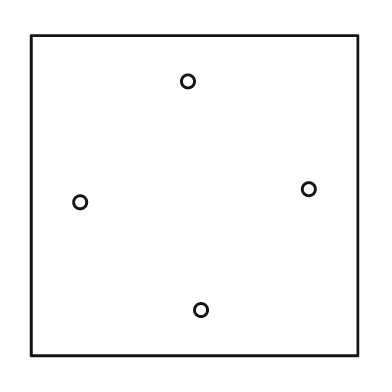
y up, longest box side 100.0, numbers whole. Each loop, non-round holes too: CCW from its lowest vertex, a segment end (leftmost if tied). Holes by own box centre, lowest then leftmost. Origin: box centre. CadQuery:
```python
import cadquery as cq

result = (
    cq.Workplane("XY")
    .moveTo(-50.0, -49.0)
    .lineTo(50.0, -49.0)
    .lineTo(50.0, 49.0)
    .lineTo(-50.0, 49.0)
    .close()
    .moveTo(2.0, -35.0)
    .circle(2.0)
    .moveTo(-35.0, -2.0)
    .circle(2.0)
    .moveTo(35.0, 2.0)
    .circle(2.0)
    .moveTo(-2.0, 35.0)
    .circle(2.0)
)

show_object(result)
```